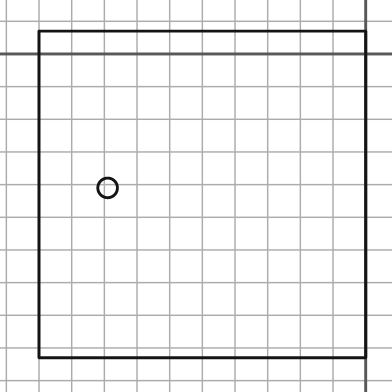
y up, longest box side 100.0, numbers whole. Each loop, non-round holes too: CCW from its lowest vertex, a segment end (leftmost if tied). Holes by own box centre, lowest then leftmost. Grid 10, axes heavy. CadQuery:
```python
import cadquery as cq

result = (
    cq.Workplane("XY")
    .moveTo(-100.0, -93.0)
    .lineTo(0.0, -93.0)
    .lineTo(0.0, 7.0)
    .lineTo(-100.0, 7.0)
    .close()
    .moveTo(-79.0, -41.0)
    .circle(3.0)
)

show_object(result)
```